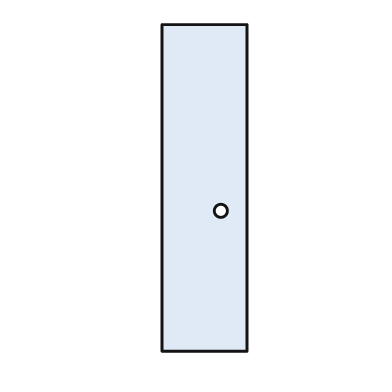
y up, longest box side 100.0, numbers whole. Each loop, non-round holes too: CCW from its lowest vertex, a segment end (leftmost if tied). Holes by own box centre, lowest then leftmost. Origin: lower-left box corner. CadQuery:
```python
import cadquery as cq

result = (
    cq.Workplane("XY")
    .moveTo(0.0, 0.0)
    .lineTo(26.0, 0.0)
    .lineTo(26.0, 100.0)
    .lineTo(0.0, 100.0)
    .close()
    .moveTo(18.0, 43.0)
    .circle(2.0)
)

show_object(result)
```